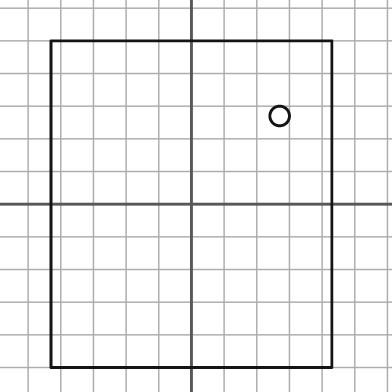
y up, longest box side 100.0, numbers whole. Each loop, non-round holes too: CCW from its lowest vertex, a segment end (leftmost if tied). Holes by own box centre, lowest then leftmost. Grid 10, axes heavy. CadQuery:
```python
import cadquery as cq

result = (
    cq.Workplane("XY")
    .moveTo(-43.0, -50.0)
    .lineTo(43.0, -50.0)
    .lineTo(43.0, 50.0)
    .lineTo(-43.0, 50.0)
    .close()
    .moveTo(27.0, 27.0)
    .circle(3.0)
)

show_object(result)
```